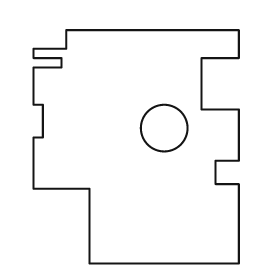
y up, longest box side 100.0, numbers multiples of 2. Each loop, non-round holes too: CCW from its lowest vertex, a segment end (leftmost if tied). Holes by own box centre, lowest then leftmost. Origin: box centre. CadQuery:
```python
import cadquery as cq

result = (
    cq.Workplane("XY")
    .moveTo(-20.0, -50.0)
    .lineTo(44.0, -50.0)
    .lineTo(44.0, -16.0)
    .lineTo(34.0, -16.0)
    .lineTo(34.0, -6.0)
    .lineTo(44.0, -6.0)
    .lineTo(44.0, 16.0)
    .lineTo(28.0, 16.0)
    .lineTo(28.0, 38.0)
    .lineTo(44.0, 38.0)
    .lineTo(44.0, 50.0)
    .lineTo(-30.0, 50.0)
    .lineTo(-30.0, 42.0)
    .lineTo(-44.0, 42.0)
    .lineTo(-44.0, 38.0)
    .lineTo(-32.0, 38.0)
    .lineTo(-32.0, 34.0)
    .lineTo(-44.0, 34.0)
    .lineTo(-44.0, 18.0)
    .lineTo(-40.0, 18.0)
    .lineTo(-40.0, 4.0)
    .lineTo(-44.0, 4.0)
    .lineTo(-44.0, -18.0)
    .lineTo(-20.0, -18.0)
    .close()
    .moveTo(12.0, 8.0)
    .circle(10.0)
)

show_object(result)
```